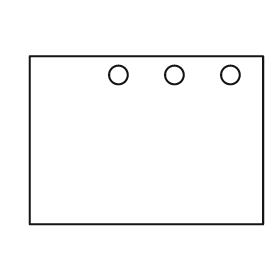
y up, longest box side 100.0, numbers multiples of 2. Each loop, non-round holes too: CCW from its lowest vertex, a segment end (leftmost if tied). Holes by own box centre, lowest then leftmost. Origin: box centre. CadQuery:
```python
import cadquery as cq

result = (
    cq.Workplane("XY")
    .moveTo(-50.0, -36.0)
    .lineTo(50.0, -36.0)
    .lineTo(50.0, 36.0)
    .lineTo(-50.0, 36.0)
    .close()
    .moveTo(-12.0, 28.0)
    .circle(4.0)
    .moveTo(12.0, 28.0)
    .circle(4.0)
    .moveTo(36.0, 28.0)
    .circle(4.0)
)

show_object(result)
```